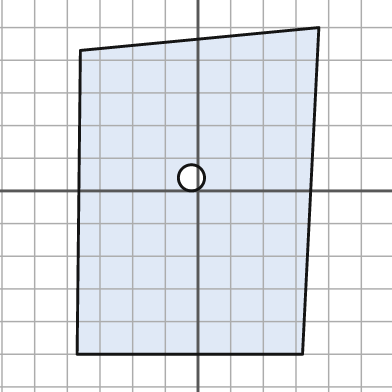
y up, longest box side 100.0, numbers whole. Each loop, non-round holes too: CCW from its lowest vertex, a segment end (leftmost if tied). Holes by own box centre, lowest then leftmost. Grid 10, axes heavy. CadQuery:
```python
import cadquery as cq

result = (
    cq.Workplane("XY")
    .moveTo(-37.0, -50.0)
    .lineTo(32.0, -50.0)
    .lineTo(37.0, 50.0)
    .lineTo(-36.0, 43.0)
    .close()
    .moveTo(-2.0, 4.0)
    .circle(4.0)
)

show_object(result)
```